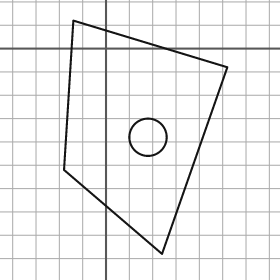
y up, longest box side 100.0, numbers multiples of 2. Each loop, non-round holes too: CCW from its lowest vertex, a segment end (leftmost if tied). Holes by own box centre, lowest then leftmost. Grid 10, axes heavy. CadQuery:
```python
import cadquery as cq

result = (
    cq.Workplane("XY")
    .moveTo(24.0, -88.0)
    .lineTo(52.0, -8.0)
    .lineTo(-14.0, 12.0)
    .lineTo(-18.0, -52.0)
    .close()
    .moveTo(18.0, -38.0)
    .circle(8.0)
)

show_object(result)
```